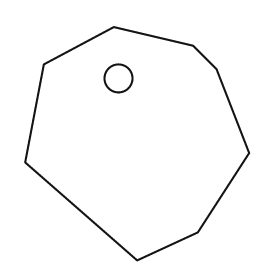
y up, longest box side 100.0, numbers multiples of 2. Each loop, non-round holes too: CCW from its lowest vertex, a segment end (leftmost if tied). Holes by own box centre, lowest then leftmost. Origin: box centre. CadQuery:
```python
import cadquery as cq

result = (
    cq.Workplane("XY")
    .moveTo(0.0, -50.0)
    .lineTo(26.0, -38.0)
    .lineTo(48.0, -4.0)
    .lineTo(34.0, 32.0)
    .lineTo(24.0, 42.0)
    .lineTo(-10.0, 50.0)
    .lineTo(-40.0, 34.0)
    .lineTo(-48.0, -8.0)
    .close()
    .moveTo(-8.0, 28.0)
    .circle(6.0)
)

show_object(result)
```